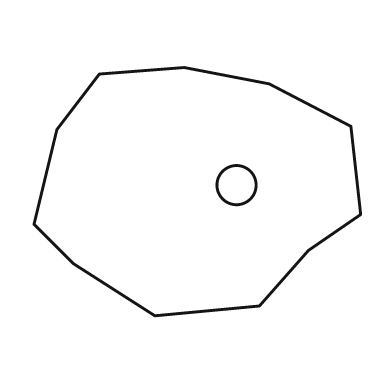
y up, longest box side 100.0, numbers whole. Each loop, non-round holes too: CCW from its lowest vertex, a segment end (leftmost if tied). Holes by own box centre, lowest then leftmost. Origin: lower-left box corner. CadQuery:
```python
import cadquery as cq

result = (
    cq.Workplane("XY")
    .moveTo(37.0, 0.0)
    .lineTo(69.0, 3.0)
    .lineTo(84.0, 20.0)
    .lineTo(100.0, 31.0)
    .lineTo(97.0, 58.0)
    .lineTo(72.0, 71.0)
    .lineTo(46.0, 76.0)
    .lineTo(20.0, 74.0)
    .lineTo(7.0, 57.0)
    .lineTo(0.0, 28.0)
    .lineTo(12.0, 16.0)
    .close()
    .moveTo(62.0, 40.0)
    .circle(6.0)
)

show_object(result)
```